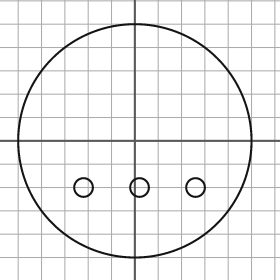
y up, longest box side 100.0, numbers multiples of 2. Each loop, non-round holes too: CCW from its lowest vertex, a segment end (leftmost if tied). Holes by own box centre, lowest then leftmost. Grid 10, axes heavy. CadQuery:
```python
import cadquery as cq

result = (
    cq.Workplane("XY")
    .moveTo(0.0, 0.0)
    .circle(50.0)
    .moveTo(-22.0, -20.0)
    .circle(4.0)
    .moveTo(2.0, -20.0)
    .circle(4.0)
    .moveTo(26.0, -20.0)
    .circle(4.0)
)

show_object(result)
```